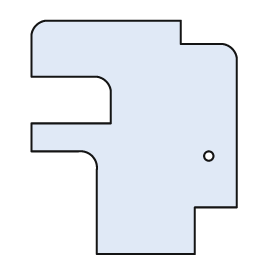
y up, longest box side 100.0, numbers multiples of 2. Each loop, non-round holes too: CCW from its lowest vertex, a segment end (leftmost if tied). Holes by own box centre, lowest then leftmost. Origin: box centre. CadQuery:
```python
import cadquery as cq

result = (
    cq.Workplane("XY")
    .moveTo(-16.0, -50.0)
    .lineTo(26.0, -50.0)
    .lineTo(26.0, -30.0)
    .lineTo(44.0, -30.0)
    .lineTo(44.0, 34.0)
    .threePointArc((42.0, 38.0), (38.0, 40.0))
    .lineTo(20.0, 40.0)
    .lineTo(20.0, 50.0)
    .lineTo(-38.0, 50.0)
    .threePointArc((-42.0, 48.0), (-44.0, 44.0))
    .lineTo(-44.0, 26.0)
    .lineTo(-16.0, 26.0)
    .threePointArc((-12.0, 24.0), (-10.0, 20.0))
    .lineTo(-10.0, 6.0)
    .lineTo(-44.0, 6.0)
    .lineTo(-44.0, -6.0)
    .lineTo(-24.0, -6.0)
    .threePointArc((-18.0, -8.0), (-16.0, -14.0))
    .close()
    .moveTo(32.0, -8.0)
    .circle(2.0)
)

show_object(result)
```